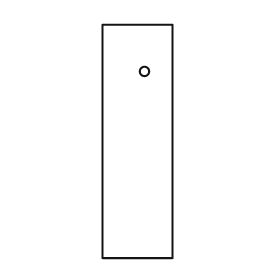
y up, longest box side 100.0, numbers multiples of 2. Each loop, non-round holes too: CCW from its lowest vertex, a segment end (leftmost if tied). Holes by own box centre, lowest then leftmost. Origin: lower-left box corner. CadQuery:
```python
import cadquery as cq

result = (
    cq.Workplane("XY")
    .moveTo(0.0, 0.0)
    .lineTo(30.0, 0.0)
    .lineTo(30.0, 100.0)
    .lineTo(0.0, 100.0)
    .close()
    .moveTo(18.0, 80.0)
    .circle(2.0)
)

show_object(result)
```